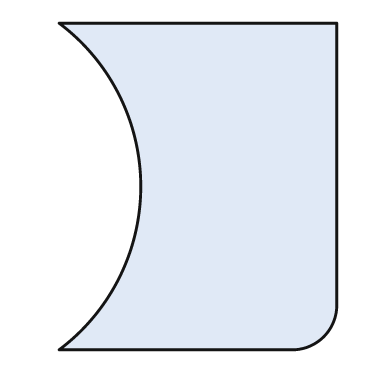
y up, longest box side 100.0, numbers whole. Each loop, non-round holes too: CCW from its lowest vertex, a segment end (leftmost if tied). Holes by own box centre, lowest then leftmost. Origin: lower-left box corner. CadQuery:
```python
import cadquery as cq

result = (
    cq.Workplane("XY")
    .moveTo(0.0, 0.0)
    .lineTo(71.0, 0.0)
    .threePointArc((81.0, 4.0), (85.0, 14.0))
    .lineTo(85.0, 100.0)
    .lineTo(0.0, 100.0)
    .threePointArc((25.0, 50.0), (0.0, 0.0))
    .close()
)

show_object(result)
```